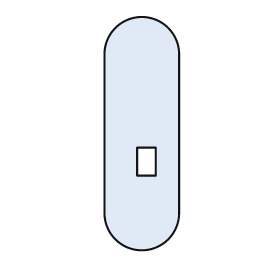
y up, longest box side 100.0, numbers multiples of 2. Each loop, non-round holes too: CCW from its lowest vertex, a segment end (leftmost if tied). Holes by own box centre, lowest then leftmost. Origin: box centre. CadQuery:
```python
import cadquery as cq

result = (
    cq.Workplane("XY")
    .moveTo(-16.0, -34.0)
    .threePointArc((0.0, -50.0), (16.0, -34.0))
    .lineTo(16.0, 34.0)
    .threePointArc((0.0, 50.0), (-16.0, 34.0))
    .close()
    .moveTo(-2.0, -18.0)
    .lineTo(6.0, -18.0)
    .lineTo(6.0, -6.0)
    .lineTo(-2.0, -6.0)
    .close()
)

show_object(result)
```